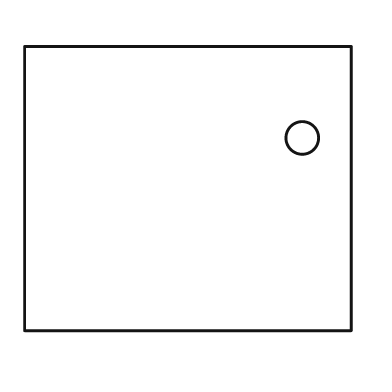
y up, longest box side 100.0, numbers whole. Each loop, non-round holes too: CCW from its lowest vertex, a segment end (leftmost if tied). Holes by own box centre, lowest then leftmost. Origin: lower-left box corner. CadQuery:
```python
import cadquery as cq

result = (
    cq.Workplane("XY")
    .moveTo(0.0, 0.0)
    .lineTo(100.0, 0.0)
    .lineTo(100.0, 87.0)
    .lineTo(0.0, 87.0)
    .close()
    .moveTo(85.0, 59.0)
    .circle(5.0)
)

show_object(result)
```